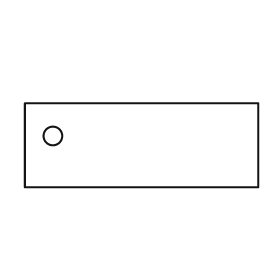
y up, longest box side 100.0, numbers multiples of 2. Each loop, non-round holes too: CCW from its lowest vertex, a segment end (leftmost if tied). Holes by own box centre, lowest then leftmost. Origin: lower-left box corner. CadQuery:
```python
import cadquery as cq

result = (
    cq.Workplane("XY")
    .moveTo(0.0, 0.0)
    .lineTo(100.0, 0.0)
    .lineTo(100.0, 36.0)
    .lineTo(0.0, 36.0)
    .close()
    .moveTo(12.0, 22.0)
    .circle(4.0)
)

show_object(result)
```